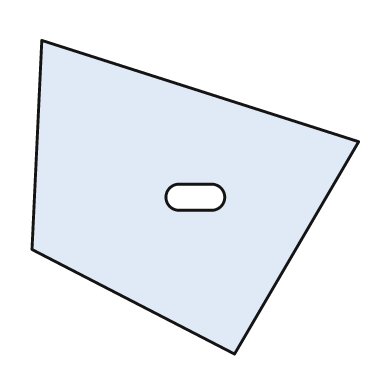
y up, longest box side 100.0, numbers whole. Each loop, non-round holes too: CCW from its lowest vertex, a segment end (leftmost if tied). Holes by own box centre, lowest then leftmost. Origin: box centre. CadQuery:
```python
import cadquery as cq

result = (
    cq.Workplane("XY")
    .moveTo(12.0, -48.0)
    .lineTo(50.0, 17.0)
    .lineTo(-47.0, 48.0)
    .lineTo(-50.0, -16.0)
    .close()
    .moveTo(-5.0, -4.0)
    .lineTo(5.0, -4.0)
    .threePointArc((9.0, 0.0), (5.0, 4.0))
    .lineTo(-5.0, 4.0)
    .threePointArc((-9.0, 0.0), (-5.0, -4.0))
    .close()
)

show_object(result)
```